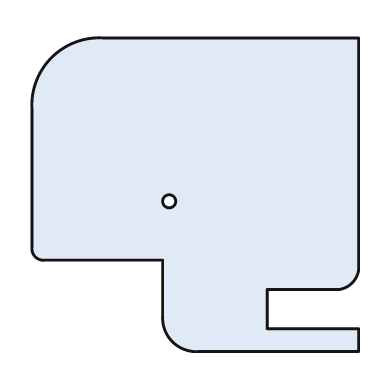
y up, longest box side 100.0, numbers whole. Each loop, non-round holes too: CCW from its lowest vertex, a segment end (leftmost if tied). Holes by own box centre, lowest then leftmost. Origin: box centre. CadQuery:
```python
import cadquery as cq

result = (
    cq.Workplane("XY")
    .moveTo(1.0, -48.0)
    .lineTo(50.0, -48.0)
    .lineTo(50.0, -41.0)
    .lineTo(22.0, -41.0)
    .lineTo(22.0, -29.0)
    .lineTo(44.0, -29.0)
    .threePointArc((48.0, -27.0), (50.0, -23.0))
    .lineTo(50.0, 48.0)
    .lineTo(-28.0, 48.0)
    .threePointArc((-44.0, 42.0), (-50.0, 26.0))
    .lineTo(-50.0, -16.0)
    .threePointArc((-49.0, -19.0), (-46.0, -20.0))
    .lineTo(-10.0, -20.0)
    .lineTo(-10.0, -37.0)
    .threePointArc((-7.0, -45.0), (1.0, -48.0))
    .close()
    .moveTo(-8.0, -2.0)
    .circle(2.0)
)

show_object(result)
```